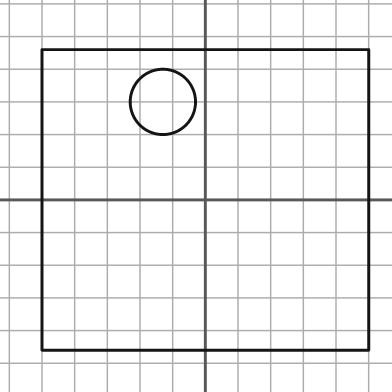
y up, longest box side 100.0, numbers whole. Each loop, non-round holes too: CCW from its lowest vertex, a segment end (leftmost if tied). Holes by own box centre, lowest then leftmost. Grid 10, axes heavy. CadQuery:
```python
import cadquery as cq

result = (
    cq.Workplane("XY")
    .moveTo(-50.0, -46.0)
    .lineTo(50.0, -46.0)
    .lineTo(50.0, 46.0)
    .lineTo(-50.0, 46.0)
    .close()
    .moveTo(-13.0, 30.0)
    .circle(10.0)
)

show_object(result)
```